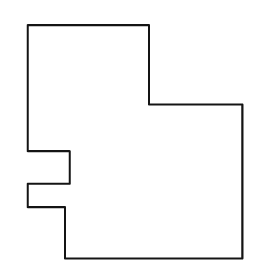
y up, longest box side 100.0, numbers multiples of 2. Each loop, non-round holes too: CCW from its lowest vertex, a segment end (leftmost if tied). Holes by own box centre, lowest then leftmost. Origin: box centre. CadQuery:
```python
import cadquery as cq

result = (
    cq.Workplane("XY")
    .moveTo(-30.0, -50.0)
    .lineTo(46.0, -50.0)
    .lineTo(46.0, 16.0)
    .lineTo(6.0, 16.0)
    .lineTo(6.0, 50.0)
    .lineTo(-46.0, 50.0)
    .lineTo(-46.0, -4.0)
    .lineTo(-28.0, -4.0)
    .lineTo(-28.0, -18.0)
    .lineTo(-46.0, -18.0)
    .lineTo(-46.0, -28.0)
    .lineTo(-30.0, -28.0)
    .close()
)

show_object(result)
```